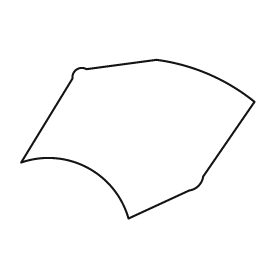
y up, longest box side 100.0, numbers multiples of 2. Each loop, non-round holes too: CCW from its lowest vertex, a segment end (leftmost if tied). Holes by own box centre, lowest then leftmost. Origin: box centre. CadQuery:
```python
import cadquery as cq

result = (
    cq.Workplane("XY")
    .moveTo(-4.0, -34.0)
    .lineTo(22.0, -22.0)
    .threePointArc((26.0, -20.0), (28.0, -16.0))
    .lineTo(50.0, 16.0)
    .threePointArc((30.0, 28.0), (8.0, 34.0))
    .lineTo(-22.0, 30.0)
    .threePointArc((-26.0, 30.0), (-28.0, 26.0))
    .lineTo(-50.0, -10.0)
    .threePointArc((-22.0, -12.0), (-4.0, -34.0))
    .close()
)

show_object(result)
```